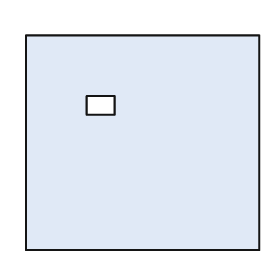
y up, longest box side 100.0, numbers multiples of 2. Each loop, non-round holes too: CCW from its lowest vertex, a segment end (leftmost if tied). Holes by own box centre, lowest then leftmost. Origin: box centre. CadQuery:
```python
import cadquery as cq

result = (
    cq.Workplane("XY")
    .moveTo(-50.0, -46.0)
    .lineTo(50.0, -46.0)
    .lineTo(50.0, 46.0)
    .lineTo(-50.0, 46.0)
    .close()
    .moveTo(-24.0, 12.0)
    .lineTo(-12.0, 12.0)
    .lineTo(-12.0, 20.0)
    .lineTo(-24.0, 20.0)
    .close()
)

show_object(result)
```